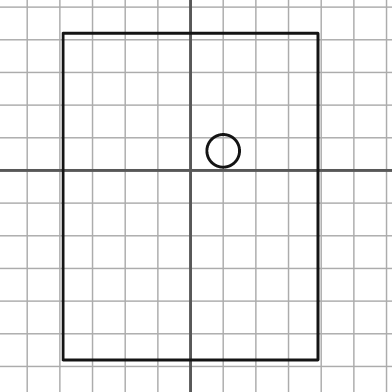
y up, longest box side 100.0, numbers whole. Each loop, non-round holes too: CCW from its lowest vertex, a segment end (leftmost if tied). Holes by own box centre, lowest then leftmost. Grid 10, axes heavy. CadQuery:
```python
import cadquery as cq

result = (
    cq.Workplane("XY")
    .moveTo(-39.0, -58.0)
    .lineTo(39.0, -58.0)
    .lineTo(39.0, 42.0)
    .lineTo(-39.0, 42.0)
    .close()
    .moveTo(10.0, 6.0)
    .circle(5.0)
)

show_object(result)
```